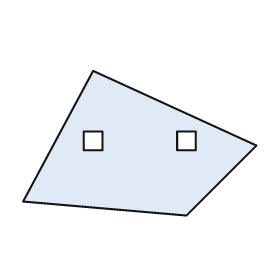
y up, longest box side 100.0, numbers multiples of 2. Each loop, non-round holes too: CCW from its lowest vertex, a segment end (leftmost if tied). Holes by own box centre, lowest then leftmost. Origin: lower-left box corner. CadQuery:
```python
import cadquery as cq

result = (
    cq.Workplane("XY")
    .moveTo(70.0, 0.0)
    .lineTo(100.0, 30.0)
    .lineTo(30.0, 62.0)
    .lineTo(0.0, 6.0)
    .close()
    .moveTo(26.0, 28.0)
    .lineTo(34.0, 28.0)
    .lineTo(34.0, 36.0)
    .lineTo(26.0, 36.0)
    .close()
    .moveTo(66.0, 28.0)
    .lineTo(74.0, 28.0)
    .lineTo(74.0, 36.0)
    .lineTo(66.0, 36.0)
    .close()
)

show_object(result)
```